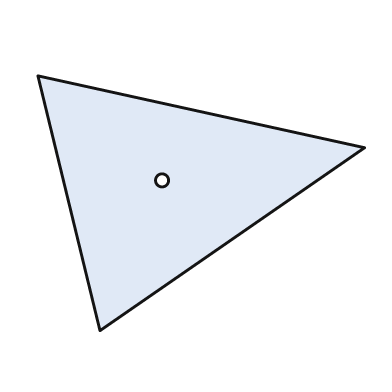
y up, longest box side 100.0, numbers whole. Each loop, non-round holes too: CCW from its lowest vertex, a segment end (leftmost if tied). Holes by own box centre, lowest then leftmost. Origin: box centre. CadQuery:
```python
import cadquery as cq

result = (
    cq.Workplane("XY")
    .moveTo(-31.0, -39.0)
    .lineTo(50.0, 17.0)
    .lineTo(-50.0, 39.0)
    .close()
    .moveTo(-12.0, 7.0)
    .circle(2.0)
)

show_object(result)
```